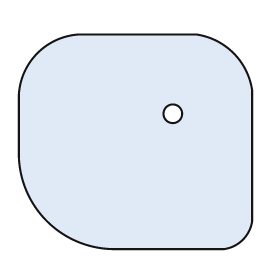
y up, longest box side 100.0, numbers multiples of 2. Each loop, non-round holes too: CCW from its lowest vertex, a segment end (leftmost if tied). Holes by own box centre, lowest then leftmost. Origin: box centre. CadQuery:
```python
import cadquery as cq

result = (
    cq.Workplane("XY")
    .moveTo(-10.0, -46.0)
    .lineTo(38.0, -46.0)
    .threePointArc((46.0, -42.0), (50.0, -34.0))
    .lineTo(50.0, 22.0)
    .threePointArc((42.0, 38.0), (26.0, 46.0))
    .lineTo(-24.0, 46.0)
    .threePointArc((-42.0, 38.0), (-50.0, 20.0))
    .lineTo(-50.0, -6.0)
    .threePointArc((-38.0, -34.0), (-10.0, -46.0))
    .close()
    .moveTo(16.0, 12.0)
    .circle(4.0)
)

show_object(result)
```